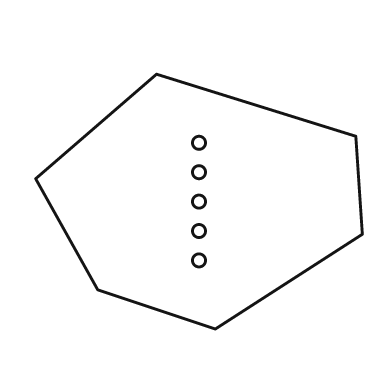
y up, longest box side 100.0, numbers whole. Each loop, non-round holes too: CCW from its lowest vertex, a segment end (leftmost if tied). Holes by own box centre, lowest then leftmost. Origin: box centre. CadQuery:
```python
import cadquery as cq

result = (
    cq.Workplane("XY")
    .moveTo(5.0, -39.0)
    .lineTo(50.0, -10.0)
    .lineTo(48.0, 20.0)
    .lineTo(-13.0, 39.0)
    .lineTo(-50.0, 7.0)
    .lineTo(-31.0, -27.0)
    .close()
    .moveTo(0.0, -18.0)
    .circle(2.0)
    .moveTo(0.0, -9.0)
    .circle(2.0)
    .moveTo(0.0, 0.0)
    .circle(2.0)
    .moveTo(0.0, 9.0)
    .circle(2.0)
    .moveTo(0.0, 18.0)
    .circle(2.0)
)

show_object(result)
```